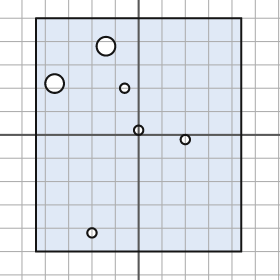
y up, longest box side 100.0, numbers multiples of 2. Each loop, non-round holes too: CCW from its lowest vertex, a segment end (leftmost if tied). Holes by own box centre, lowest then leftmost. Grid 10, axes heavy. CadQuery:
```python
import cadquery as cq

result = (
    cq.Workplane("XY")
    .moveTo(-44.0, -50.0)
    .lineTo(44.0, -50.0)
    .lineTo(44.0, 50.0)
    .lineTo(-44.0, 50.0)
    .close()
    .moveTo(-20.0, -42.0)
    .circle(2.0)
    .moveTo(20.0, -2.0)
    .circle(2.0)
    .moveTo(0.0, 2.0)
    .circle(2.0)
    .moveTo(-6.0, 20.0)
    .circle(2.0)
    .moveTo(-36.0, 22.0)
    .circle(4.0)
    .moveTo(-14.0, 38.0)
    .circle(4.0)
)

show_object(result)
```